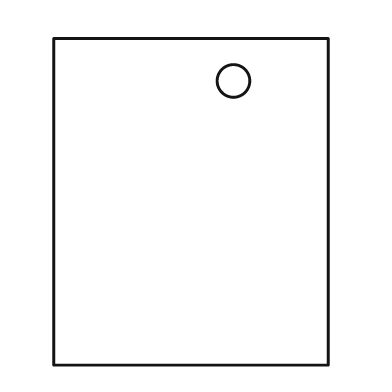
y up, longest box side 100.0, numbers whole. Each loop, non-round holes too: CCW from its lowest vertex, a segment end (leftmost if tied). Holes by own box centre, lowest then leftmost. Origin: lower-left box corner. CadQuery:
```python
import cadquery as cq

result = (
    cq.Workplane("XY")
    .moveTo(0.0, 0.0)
    .lineTo(84.0, 0.0)
    .lineTo(84.0, 100.0)
    .lineTo(0.0, 100.0)
    .close()
    .moveTo(55.0, 87.0)
    .circle(5.0)
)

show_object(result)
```